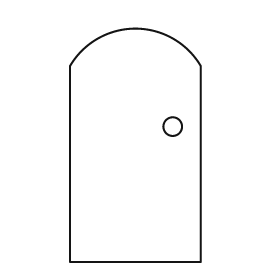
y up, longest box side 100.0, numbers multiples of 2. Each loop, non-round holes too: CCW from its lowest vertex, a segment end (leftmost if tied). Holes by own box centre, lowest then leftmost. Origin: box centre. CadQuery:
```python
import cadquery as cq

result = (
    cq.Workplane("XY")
    .moveTo(-28.0, -50.0)
    .lineTo(28.0, -50.0)
    .lineTo(28.0, 34.0)
    .threePointArc((0.0, 50.0), (-28.0, 34.0))
    .close()
    .moveTo(16.0, 8.0)
    .circle(4.0)
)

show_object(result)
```